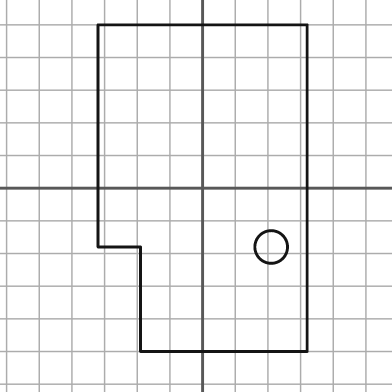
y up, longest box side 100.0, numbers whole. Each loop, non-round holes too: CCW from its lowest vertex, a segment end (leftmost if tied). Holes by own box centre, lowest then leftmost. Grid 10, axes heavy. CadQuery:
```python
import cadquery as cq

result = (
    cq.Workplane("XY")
    .moveTo(-19.0, -50.0)
    .lineTo(32.0, -50.0)
    .lineTo(32.0, 50.0)
    .lineTo(-32.0, 50.0)
    .lineTo(-32.0, -18.0)
    .lineTo(-19.0, -18.0)
    .close()
    .moveTo(21.0, -18.0)
    .circle(5.0)
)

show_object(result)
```